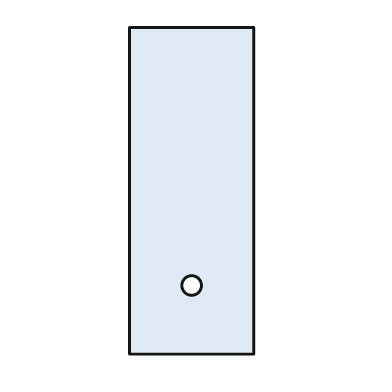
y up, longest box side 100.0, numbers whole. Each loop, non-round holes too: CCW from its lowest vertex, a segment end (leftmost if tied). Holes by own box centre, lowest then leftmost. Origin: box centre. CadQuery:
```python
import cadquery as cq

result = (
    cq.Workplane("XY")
    .moveTo(-19.0, -50.0)
    .lineTo(19.0, -50.0)
    .lineTo(19.0, 50.0)
    .lineTo(-19.0, 50.0)
    .close()
    .moveTo(0.0, -29.0)
    .circle(3.0)
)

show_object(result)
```